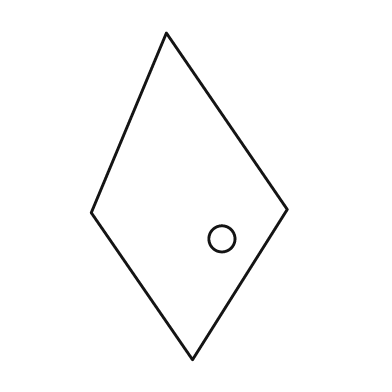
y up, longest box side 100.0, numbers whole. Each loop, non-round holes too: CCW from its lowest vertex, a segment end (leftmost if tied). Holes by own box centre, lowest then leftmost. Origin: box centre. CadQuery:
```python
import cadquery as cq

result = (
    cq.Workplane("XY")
    .moveTo(1.0, -50.0)
    .lineTo(30.0, -4.0)
    .lineTo(-7.0, 50.0)
    .lineTo(-30.0, -5.0)
    .close()
    .moveTo(10.0, -13.0)
    .circle(4.0)
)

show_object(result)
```